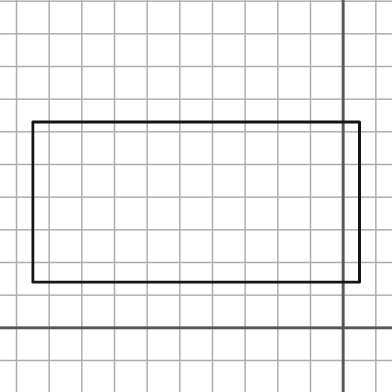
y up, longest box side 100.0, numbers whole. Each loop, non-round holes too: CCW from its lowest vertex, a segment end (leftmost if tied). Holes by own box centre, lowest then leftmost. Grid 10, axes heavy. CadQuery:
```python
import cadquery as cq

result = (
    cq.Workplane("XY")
    .moveTo(-95.0, 14.0)
    .lineTo(5.0, 14.0)
    .lineTo(5.0, 63.0)
    .lineTo(-95.0, 63.0)
    .close()
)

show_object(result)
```